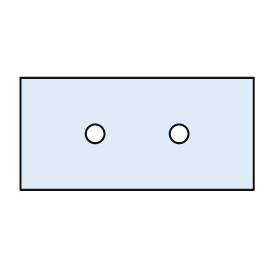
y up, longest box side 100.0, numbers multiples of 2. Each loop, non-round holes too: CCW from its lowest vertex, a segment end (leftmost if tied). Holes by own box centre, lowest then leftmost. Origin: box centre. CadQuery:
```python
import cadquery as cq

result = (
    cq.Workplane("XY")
    .moveTo(-50.0, -24.0)
    .lineTo(50.0, -24.0)
    .lineTo(50.0, 24.0)
    .lineTo(-50.0, 24.0)
    .close()
    .moveTo(-18.0, 0.0)
    .circle(4.0)
    .moveTo(18.0, 0.0)
    .circle(4.0)
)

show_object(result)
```